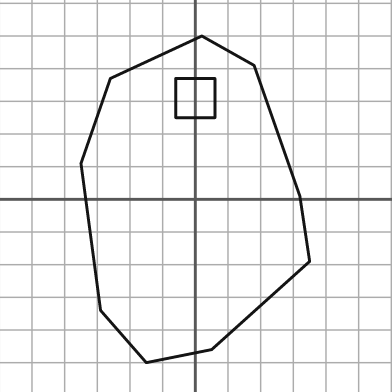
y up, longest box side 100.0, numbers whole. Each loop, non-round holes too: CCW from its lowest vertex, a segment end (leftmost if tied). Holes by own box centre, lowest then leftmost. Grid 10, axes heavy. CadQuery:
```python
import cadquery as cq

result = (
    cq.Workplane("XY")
    .moveTo(-15.0, -50.0)
    .lineTo(5.0, -46.0)
    .lineTo(35.0, -19.0)
    .lineTo(32.0, 1.0)
    .lineTo(18.0, 41.0)
    .lineTo(2.0, 50.0)
    .lineTo(-26.0, 37.0)
    .lineTo(-35.0, 11.0)
    .lineTo(-29.0, -34.0)
    .close()
    .moveTo(-6.0, 25.0)
    .lineTo(6.0, 25.0)
    .lineTo(6.0, 37.0)
    .lineTo(-6.0, 37.0)
    .close()
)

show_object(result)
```